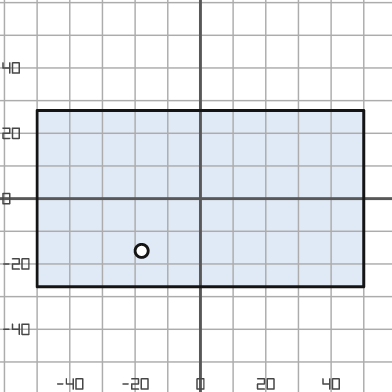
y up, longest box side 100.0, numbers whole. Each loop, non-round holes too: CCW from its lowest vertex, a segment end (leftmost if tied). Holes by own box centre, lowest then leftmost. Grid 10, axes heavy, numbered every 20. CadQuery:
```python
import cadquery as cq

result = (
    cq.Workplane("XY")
    .moveTo(-50.0, -27.0)
    .lineTo(50.0, -27.0)
    .lineTo(50.0, 27.0)
    .lineTo(-50.0, 27.0)
    .close()
    .moveTo(-18.0, -16.0)
    .circle(2.0)
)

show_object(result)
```